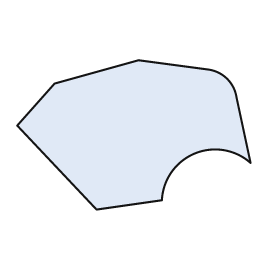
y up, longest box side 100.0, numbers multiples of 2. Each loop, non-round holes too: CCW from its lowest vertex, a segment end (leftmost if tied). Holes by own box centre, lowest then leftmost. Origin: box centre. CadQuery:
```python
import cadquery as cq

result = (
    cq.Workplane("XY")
    .moveTo(-16.0, -32.0)
    .lineTo(12.0, -28.0)
    .threePointArc((26.0, -8.0), (50.0, -12.0))
    .lineTo(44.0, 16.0)
    .threePointArc((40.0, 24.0), (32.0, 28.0))
    .lineTo(2.0, 32.0)
    .lineTo(-34.0, 22.0)
    .lineTo(-50.0, 4.0)
    .close()
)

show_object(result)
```